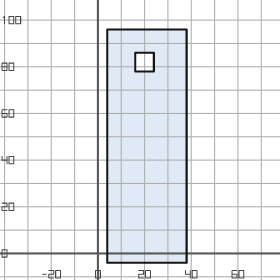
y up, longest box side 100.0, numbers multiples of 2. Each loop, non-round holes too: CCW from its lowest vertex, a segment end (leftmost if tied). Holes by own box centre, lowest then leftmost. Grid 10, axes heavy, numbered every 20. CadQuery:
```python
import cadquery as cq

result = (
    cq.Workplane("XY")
    .moveTo(4.0, -4.0)
    .lineTo(38.0, -4.0)
    .lineTo(38.0, 96.0)
    .lineTo(4.0, 96.0)
    .close()
    .moveTo(16.0, 78.0)
    .lineTo(24.0, 78.0)
    .lineTo(24.0, 86.0)
    .lineTo(16.0, 86.0)
    .close()
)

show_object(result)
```